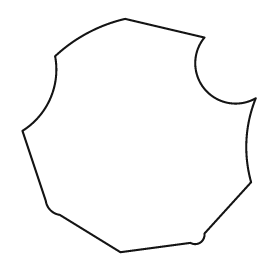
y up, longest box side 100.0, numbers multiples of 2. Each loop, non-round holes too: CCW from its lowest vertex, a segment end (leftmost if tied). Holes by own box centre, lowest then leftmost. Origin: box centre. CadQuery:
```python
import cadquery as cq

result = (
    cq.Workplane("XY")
    .moveTo(-8.0, -50.0)
    .lineTo(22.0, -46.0)
    .threePointArc((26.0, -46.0), (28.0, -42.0))
    .lineTo(48.0, -20.0)
    .threePointArc((46.0, -2.0), (50.0, 16.0))
    .threePointArc((28.0, 20.0), (28.0, 42.0))
    .lineTo(-6.0, 50.0)
    .threePointArc((-22.0, 44.0), (-36.0, 34.0))
    .threePointArc((-38.0, 16.0), (-50.0, 2.0))
    .lineTo(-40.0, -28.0)
    .threePointArc((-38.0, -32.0), (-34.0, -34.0))
    .close()
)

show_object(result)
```